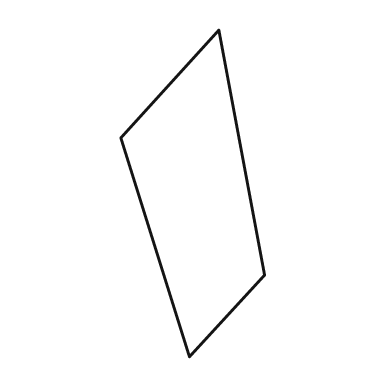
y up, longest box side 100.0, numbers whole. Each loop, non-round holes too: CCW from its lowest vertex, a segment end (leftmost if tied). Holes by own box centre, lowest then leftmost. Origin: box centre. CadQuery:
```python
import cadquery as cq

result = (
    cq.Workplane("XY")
    .moveTo(-1.0, -50.0)
    .lineTo(22.0, -25.0)
    .lineTo(8.0, 50.0)
    .lineTo(-22.0, 17.0)
    .close()
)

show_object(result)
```